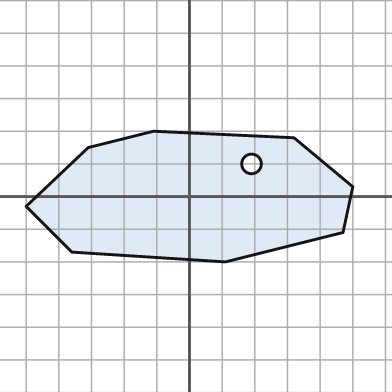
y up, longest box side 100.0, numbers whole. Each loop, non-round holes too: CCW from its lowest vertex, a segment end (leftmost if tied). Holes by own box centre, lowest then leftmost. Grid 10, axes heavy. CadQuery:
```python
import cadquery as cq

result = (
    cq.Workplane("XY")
    .moveTo(11.0, -20.0)
    .lineTo(47.0, -11.0)
    .lineTo(50.0, 3.0)
    .lineTo(32.0, 18.0)
    .lineTo(-11.0, 20.0)
    .lineTo(-31.0, 15.0)
    .lineTo(-50.0, -3.0)
    .lineTo(-36.0, -17.0)
    .close()
    .moveTo(19.0, 10.0)
    .circle(3.0)
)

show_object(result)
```